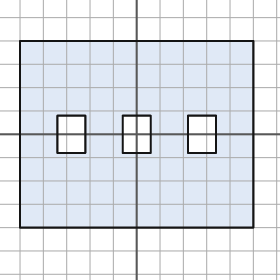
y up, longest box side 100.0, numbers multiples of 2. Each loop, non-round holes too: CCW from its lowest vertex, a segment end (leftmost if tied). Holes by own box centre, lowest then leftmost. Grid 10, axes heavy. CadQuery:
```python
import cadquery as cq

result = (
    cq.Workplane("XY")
    .moveTo(-50.0, -40.0)
    .lineTo(50.0, -40.0)
    .lineTo(50.0, 40.0)
    .lineTo(-50.0, 40.0)
    .close()
    .moveTo(-34.0, -8.0)
    .lineTo(-22.0, -8.0)
    .lineTo(-22.0, 8.0)
    .lineTo(-34.0, 8.0)
    .close()
    .moveTo(-6.0, -8.0)
    .lineTo(6.0, -8.0)
    .lineTo(6.0, 8.0)
    .lineTo(-6.0, 8.0)
    .close()
    .moveTo(22.0, -8.0)
    .lineTo(34.0, -8.0)
    .lineTo(34.0, 8.0)
    .lineTo(22.0, 8.0)
    .close()
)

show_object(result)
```